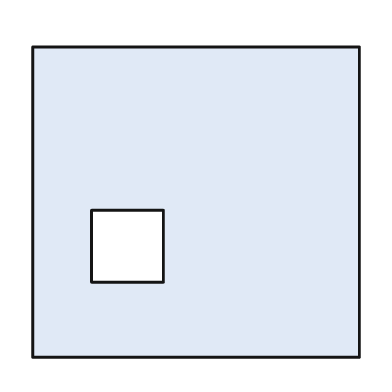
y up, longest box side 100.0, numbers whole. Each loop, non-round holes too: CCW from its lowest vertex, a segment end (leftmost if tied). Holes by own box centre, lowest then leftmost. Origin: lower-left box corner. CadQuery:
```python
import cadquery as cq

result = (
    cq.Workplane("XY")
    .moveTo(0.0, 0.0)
    .lineTo(100.0, 0.0)
    .lineTo(100.0, 95.0)
    .lineTo(0.0, 95.0)
    .close()
    .moveTo(18.0, 23.0)
    .lineTo(40.0, 23.0)
    .lineTo(40.0, 45.0)
    .lineTo(18.0, 45.0)
    .close()
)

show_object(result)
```